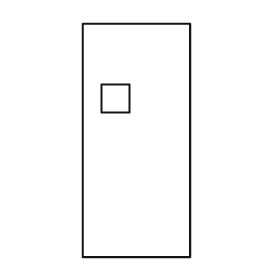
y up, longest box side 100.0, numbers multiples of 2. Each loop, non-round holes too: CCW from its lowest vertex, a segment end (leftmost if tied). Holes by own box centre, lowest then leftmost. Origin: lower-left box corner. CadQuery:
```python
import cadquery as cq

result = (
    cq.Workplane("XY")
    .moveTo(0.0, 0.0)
    .lineTo(46.0, 0.0)
    .lineTo(46.0, 100.0)
    .lineTo(0.0, 100.0)
    .close()
    .moveTo(8.0, 62.0)
    .lineTo(20.0, 62.0)
    .lineTo(20.0, 74.0)
    .lineTo(8.0, 74.0)
    .close()
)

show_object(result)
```